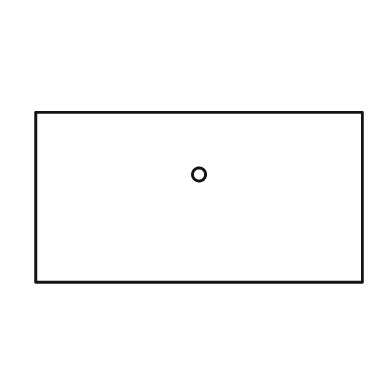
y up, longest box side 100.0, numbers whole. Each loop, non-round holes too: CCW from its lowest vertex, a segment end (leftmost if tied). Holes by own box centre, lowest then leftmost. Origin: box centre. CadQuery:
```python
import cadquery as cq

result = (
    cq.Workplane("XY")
    .moveTo(-50.0, -26.0)
    .lineTo(50.0, -26.0)
    .lineTo(50.0, 26.0)
    .lineTo(-50.0, 26.0)
    .close()
    .moveTo(0.0, 7.0)
    .circle(2.0)
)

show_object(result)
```